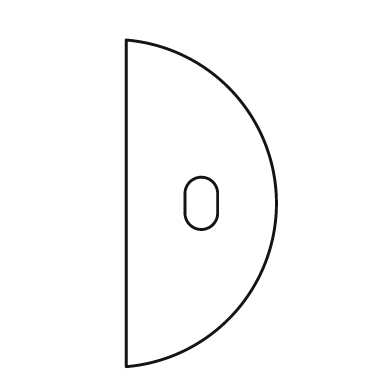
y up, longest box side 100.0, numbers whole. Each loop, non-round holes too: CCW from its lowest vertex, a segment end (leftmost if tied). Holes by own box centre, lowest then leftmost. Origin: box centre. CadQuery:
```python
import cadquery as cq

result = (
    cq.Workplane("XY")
    .moveTo(-23.0, -50.0)
    .threePointArc((23.0, 0.0), (-23.0, 50.0))
    .close()
    .moveTo(-5.0, -3.0)
    .threePointArc((0.0, -8.0), (5.0, -3.0))
    .lineTo(5.0, 3.0)
    .threePointArc((0.0, 8.0), (-5.0, 3.0))
    .close()
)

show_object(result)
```